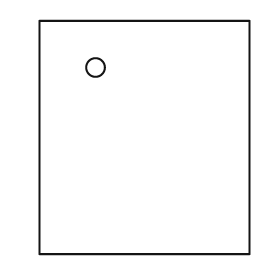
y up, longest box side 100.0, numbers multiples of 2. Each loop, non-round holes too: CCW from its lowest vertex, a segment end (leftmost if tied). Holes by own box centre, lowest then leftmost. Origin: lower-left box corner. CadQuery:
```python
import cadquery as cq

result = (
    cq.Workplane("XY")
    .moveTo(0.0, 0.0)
    .lineTo(90.0, 0.0)
    .lineTo(90.0, 100.0)
    .lineTo(0.0, 100.0)
    .close()
    .moveTo(24.0, 80.0)
    .circle(4.0)
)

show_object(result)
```